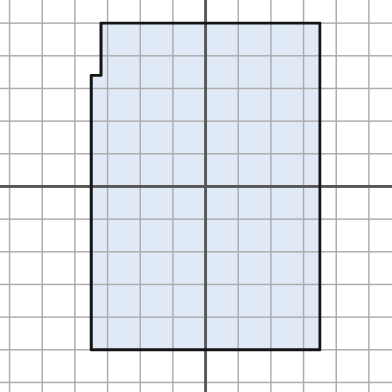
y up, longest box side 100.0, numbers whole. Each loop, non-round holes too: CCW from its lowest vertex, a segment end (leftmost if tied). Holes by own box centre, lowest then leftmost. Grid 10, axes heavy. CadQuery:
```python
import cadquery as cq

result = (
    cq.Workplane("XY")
    .moveTo(-35.0, -50.0)
    .lineTo(35.0, -50.0)
    .lineTo(35.0, 50.0)
    .lineTo(-32.0, 50.0)
    .lineTo(-32.0, 34.0)
    .lineTo(-35.0, 34.0)
    .close()
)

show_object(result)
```